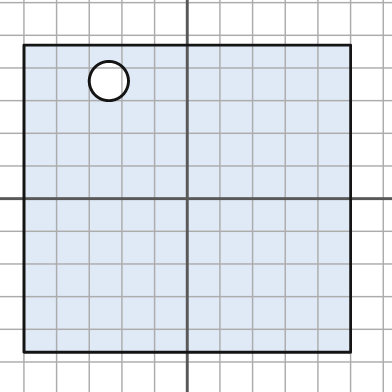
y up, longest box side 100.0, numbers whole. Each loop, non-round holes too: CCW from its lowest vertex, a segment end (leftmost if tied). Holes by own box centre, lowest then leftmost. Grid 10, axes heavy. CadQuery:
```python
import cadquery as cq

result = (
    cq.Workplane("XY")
    .moveTo(-50.0, -47.0)
    .lineTo(50.0, -47.0)
    .lineTo(50.0, 47.0)
    .lineTo(-50.0, 47.0)
    .close()
    .moveTo(-24.0, 36.0)
    .circle(6.0)
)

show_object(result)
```